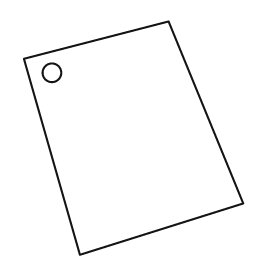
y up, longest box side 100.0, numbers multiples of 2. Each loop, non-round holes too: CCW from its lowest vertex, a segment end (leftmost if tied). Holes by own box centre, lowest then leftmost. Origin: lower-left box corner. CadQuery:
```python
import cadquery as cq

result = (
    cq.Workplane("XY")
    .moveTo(24.0, 0.0)
    .lineTo(94.0, 22.0)
    .lineTo(62.0, 100.0)
    .lineTo(0.0, 84.0)
    .close()
    .moveTo(12.0, 78.0)
    .circle(4.0)
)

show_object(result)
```